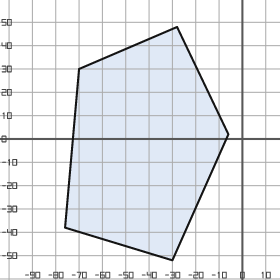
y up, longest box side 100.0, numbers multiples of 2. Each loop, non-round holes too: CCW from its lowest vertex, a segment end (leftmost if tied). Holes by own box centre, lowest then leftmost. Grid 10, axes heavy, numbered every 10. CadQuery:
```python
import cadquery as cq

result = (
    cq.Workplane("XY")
    .moveTo(-30.0, -52.0)
    .lineTo(-6.0, 2.0)
    .lineTo(-28.0, 48.0)
    .lineTo(-70.0, 30.0)
    .lineTo(-76.0, -38.0)
    .close()
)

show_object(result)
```